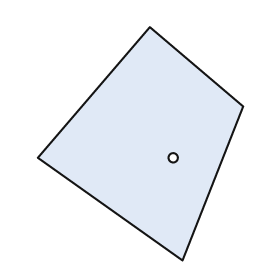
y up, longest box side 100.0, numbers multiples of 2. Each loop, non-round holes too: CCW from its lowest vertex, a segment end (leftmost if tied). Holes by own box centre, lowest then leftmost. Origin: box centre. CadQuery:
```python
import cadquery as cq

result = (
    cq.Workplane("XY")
    .moveTo(18.0, -50.0)
    .lineTo(44.0, 16.0)
    .lineTo(4.0, 50.0)
    .lineTo(-44.0, -6.0)
    .close()
    .moveTo(14.0, -6.0)
    .circle(2.0)
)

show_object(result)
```